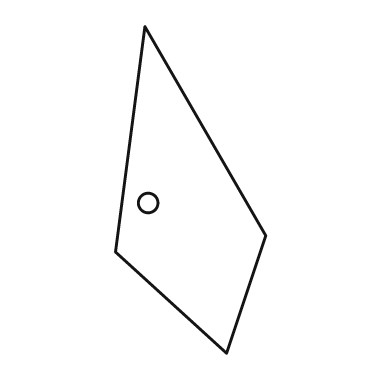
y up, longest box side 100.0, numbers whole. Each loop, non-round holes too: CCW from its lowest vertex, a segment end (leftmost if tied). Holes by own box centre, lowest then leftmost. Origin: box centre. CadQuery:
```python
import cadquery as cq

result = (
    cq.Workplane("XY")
    .moveTo(11.0, -50.0)
    .lineTo(23.0, -14.0)
    .lineTo(-14.0, 50.0)
    .lineTo(-23.0, -19.0)
    .close()
    .moveTo(-13.0, -4.0)
    .circle(3.0)
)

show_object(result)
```